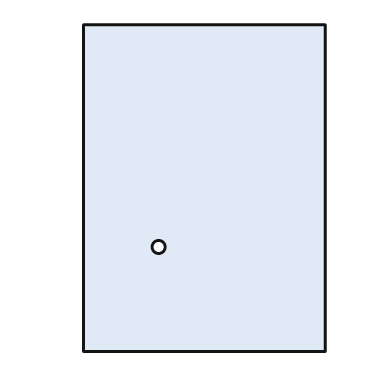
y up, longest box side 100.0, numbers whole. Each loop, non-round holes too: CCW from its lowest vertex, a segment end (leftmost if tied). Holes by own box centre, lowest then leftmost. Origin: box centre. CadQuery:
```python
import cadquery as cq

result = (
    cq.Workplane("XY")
    .moveTo(-37.0, -50.0)
    .lineTo(37.0, -50.0)
    .lineTo(37.0, 50.0)
    .lineTo(-37.0, 50.0)
    .close()
    .moveTo(-14.0, -18.0)
    .circle(2.0)
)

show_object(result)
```